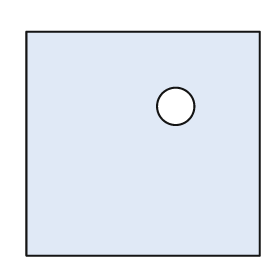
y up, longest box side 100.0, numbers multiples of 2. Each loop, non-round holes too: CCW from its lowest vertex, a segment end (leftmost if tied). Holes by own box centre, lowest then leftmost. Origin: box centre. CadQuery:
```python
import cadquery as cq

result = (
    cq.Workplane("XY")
    .moveTo(-50.0, -48.0)
    .lineTo(50.0, -48.0)
    .lineTo(50.0, 48.0)
    .lineTo(-50.0, 48.0)
    .close()
    .moveTo(14.0, 16.0)
    .circle(8.0)
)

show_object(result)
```